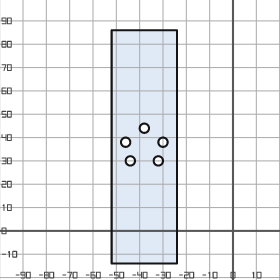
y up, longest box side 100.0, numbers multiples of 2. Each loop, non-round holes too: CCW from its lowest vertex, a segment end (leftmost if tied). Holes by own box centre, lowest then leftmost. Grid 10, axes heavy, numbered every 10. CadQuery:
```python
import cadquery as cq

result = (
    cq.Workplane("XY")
    .moveTo(-52.0, -14.0)
    .lineTo(-24.0, -14.0)
    .lineTo(-24.0, 86.0)
    .lineTo(-52.0, 86.0)
    .close()
    .moveTo(-44.0, 30.0)
    .circle(2.0)
    .moveTo(-32.0, 30.0)
    .circle(2.0)
    .moveTo(-46.0, 38.0)
    .circle(2.0)
    .moveTo(-30.0, 38.0)
    .circle(2.0)
    .moveTo(-38.0, 44.0)
    .circle(2.0)
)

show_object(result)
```